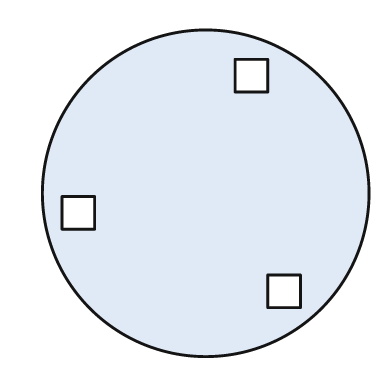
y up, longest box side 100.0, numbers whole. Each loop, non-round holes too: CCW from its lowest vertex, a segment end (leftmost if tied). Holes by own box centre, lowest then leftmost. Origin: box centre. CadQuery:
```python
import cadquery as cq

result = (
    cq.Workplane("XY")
    .moveTo(0.0, 0.0)
    .circle(50.0)
    .moveTo(19.0, -35.0)
    .lineTo(29.0, -35.0)
    .lineTo(29.0, -25.0)
    .lineTo(19.0, -25.0)
    .close()
    .moveTo(-44.0, -11.0)
    .lineTo(-34.0, -11.0)
    .lineTo(-34.0, -1.0)
    .lineTo(-44.0, -1.0)
    .close()
    .moveTo(9.0, 31.0)
    .lineTo(19.0, 31.0)
    .lineTo(19.0, 41.0)
    .lineTo(9.0, 41.0)
    .close()
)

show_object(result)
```